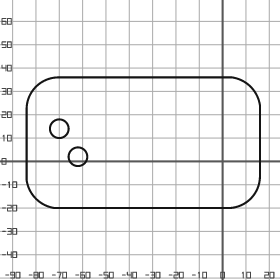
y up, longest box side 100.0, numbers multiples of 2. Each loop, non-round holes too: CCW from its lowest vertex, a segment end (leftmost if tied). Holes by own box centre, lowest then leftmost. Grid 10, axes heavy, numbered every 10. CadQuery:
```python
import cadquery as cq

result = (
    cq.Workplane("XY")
    .moveTo(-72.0, -20.0)
    .lineTo(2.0, -20.0)
    .threePointArc((12.0, -16.0), (16.0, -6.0))
    .lineTo(16.0, 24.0)
    .threePointArc((12.0, 32.0), (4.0, 36.0))
    .lineTo(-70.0, 36.0)
    .threePointArc((-80.0, 32.0), (-84.0, 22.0))
    .lineTo(-84.0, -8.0)
    .threePointArc((-80.0, -16.0), (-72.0, -20.0))
    .close()
    .moveTo(-62.0, 2.0)
    .circle(4.0)
    .moveTo(-70.0, 14.0)
    .circle(4.0)
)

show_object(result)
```